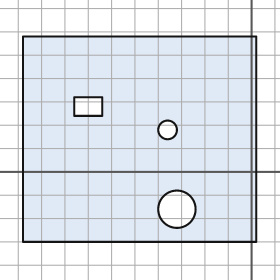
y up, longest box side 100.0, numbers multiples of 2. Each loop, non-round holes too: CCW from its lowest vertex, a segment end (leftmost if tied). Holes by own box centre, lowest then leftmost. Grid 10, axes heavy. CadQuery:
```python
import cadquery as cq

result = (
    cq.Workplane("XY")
    .moveTo(-98.0, -30.0)
    .lineTo(2.0, -30.0)
    .lineTo(2.0, 58.0)
    .lineTo(-98.0, 58.0)
    .close()
    .moveTo(-32.0, -16.0)
    .circle(8.0)
    .moveTo(-36.0, 18.0)
    .circle(4.0)
    .moveTo(-76.0, 24.0)
    .lineTo(-64.0, 24.0)
    .lineTo(-64.0, 32.0)
    .lineTo(-76.0, 32.0)
    .close()
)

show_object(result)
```